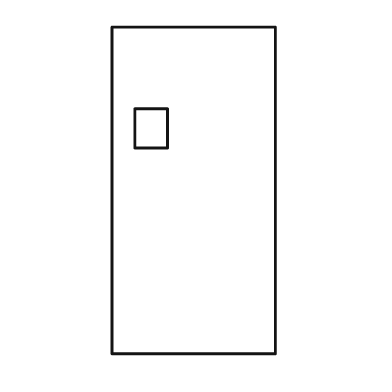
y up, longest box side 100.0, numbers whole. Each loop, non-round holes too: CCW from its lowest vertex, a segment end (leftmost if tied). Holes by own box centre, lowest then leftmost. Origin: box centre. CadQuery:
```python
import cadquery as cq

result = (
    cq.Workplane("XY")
    .moveTo(-25.0, -50.0)
    .lineTo(25.0, -50.0)
    .lineTo(25.0, 50.0)
    .lineTo(-25.0, 50.0)
    .close()
    .moveTo(-18.0, 13.0)
    .lineTo(-8.0, 13.0)
    .lineTo(-8.0, 25.0)
    .lineTo(-18.0, 25.0)
    .close()
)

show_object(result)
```